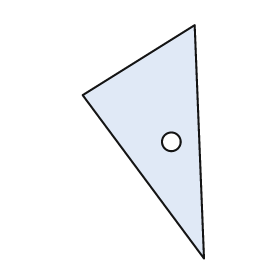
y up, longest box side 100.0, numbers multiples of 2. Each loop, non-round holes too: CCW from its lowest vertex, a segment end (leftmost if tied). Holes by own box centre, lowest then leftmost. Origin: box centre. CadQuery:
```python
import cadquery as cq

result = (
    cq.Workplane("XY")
    .moveTo(26.0, -50.0)
    .lineTo(22.0, 50.0)
    .lineTo(-26.0, 20.0)
    .close()
    .moveTo(12.0, 0.0)
    .circle(4.0)
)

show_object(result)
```